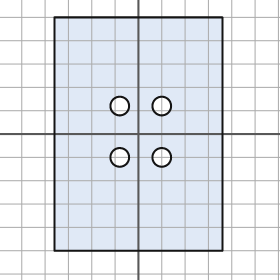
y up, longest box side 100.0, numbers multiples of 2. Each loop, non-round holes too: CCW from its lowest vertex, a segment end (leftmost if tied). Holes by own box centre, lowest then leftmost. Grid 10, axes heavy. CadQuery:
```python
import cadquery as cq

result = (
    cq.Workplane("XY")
    .moveTo(-36.0, -50.0)
    .lineTo(36.0, -50.0)
    .lineTo(36.0, 50.0)
    .lineTo(-36.0, 50.0)
    .close()
    .moveTo(-8.0, -10.0)
    .circle(4.0)
    .moveTo(10.0, -10.0)
    .circle(4.0)
    .moveTo(-8.0, 12.0)
    .circle(4.0)
    .moveTo(10.0, 12.0)
    .circle(4.0)
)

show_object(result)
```